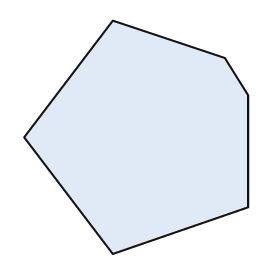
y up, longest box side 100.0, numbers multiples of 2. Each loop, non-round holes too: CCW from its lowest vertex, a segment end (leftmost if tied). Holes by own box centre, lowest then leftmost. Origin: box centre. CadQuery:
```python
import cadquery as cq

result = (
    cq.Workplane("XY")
    .moveTo(-10.0, -50.0)
    .lineTo(48.0, -30.0)
    .lineTo(48.0, 18.0)
    .lineTo(38.0, 34.0)
    .lineTo(-10.0, 50.0)
    .lineTo(-48.0, 0.0)
    .close()
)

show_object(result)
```